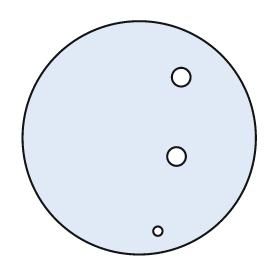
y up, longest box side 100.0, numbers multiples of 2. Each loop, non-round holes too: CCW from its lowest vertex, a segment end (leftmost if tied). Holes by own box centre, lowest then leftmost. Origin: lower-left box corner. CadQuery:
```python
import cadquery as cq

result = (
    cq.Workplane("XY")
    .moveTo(50.0, 50.0)
    .circle(50.0)
    .moveTo(58.0, 10.0)
    .circle(2.0)
    .moveTo(66.0, 42.0)
    .circle(4.0)
    .moveTo(68.0, 76.0)
    .circle(4.0)
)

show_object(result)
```